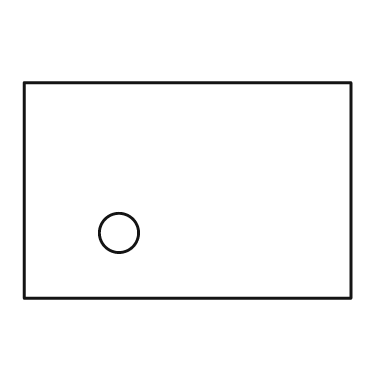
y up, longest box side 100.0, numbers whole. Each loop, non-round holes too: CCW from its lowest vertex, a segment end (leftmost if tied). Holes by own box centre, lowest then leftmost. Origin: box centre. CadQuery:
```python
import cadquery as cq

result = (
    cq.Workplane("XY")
    .moveTo(-50.0, -33.0)
    .lineTo(50.0, -33.0)
    .lineTo(50.0, 33.0)
    .lineTo(-50.0, 33.0)
    .close()
    .moveTo(-21.0, -13.0)
    .circle(6.0)
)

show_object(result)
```